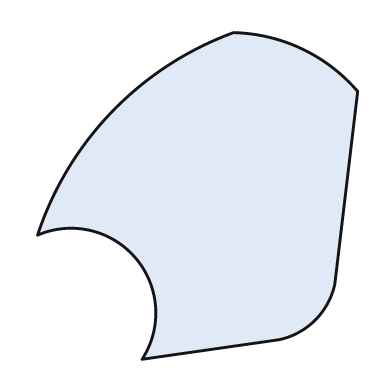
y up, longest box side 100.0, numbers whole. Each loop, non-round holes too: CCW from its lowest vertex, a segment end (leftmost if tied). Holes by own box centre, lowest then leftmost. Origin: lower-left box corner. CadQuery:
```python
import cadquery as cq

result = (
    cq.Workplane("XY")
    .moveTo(32.0, 0.0)
    .lineTo(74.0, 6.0)
    .threePointArc((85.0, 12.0), (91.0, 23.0))
    .lineTo(98.0, 82.0)
    .threePointArc((81.0, 95.0), (60.0, 100.0))
    .threePointArc((23.0, 76.0), (0.0, 38.0))
    .threePointArc((30.0, 31.0), (32.0, 0.0))
    .close()
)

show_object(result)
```